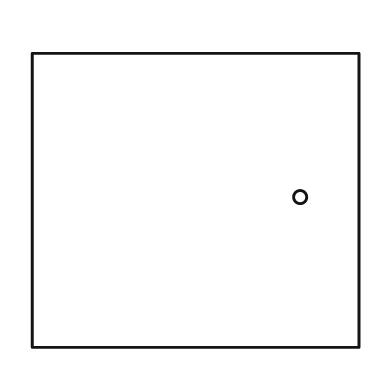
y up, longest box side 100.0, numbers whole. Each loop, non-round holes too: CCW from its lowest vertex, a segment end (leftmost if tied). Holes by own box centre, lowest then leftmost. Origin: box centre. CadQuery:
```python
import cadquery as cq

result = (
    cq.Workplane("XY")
    .moveTo(-50.0, -45.0)
    .lineTo(50.0, -45.0)
    .lineTo(50.0, 45.0)
    .lineTo(-50.0, 45.0)
    .close()
    .moveTo(32.0, 1.0)
    .circle(2.0)
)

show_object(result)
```